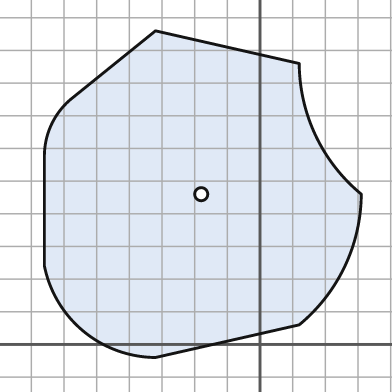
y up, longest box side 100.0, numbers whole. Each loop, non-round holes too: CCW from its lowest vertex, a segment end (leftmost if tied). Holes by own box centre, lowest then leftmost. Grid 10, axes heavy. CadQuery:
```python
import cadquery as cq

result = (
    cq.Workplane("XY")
    .moveTo(-32.0, -4.0)
    .lineTo(12.0, 6.0)
    .threePointArc((26.0, 24.0), (31.0, 46.0))
    .threePointArc((17.0, 64.0), (12.0, 86.0))
    .lineTo(-32.0, 96.0)
    .lineTo(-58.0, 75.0)
    .threePointArc((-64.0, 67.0), (-66.0, 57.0))
    .lineTo(-66.0, 24.0)
    .threePointArc((-54.0, 4.0), (-32.0, -4.0))
    .close()
    .moveTo(-18.0, 46.0)
    .circle(2.0)
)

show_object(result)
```